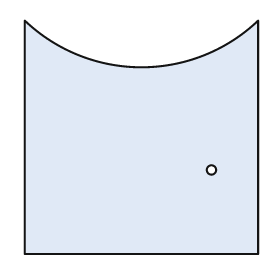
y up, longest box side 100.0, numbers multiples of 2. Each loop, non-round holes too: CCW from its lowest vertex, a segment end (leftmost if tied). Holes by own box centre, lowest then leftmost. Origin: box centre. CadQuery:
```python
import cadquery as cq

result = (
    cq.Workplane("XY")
    .moveTo(-50.0, -50.0)
    .lineTo(50.0, -50.0)
    .lineTo(50.0, 50.0)
    .threePointArc((0.0, 30.0), (-50.0, 50.0))
    .close()
    .moveTo(30.0, -14.0)
    .circle(2.0)
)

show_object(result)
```